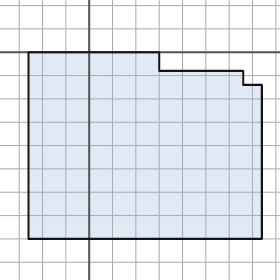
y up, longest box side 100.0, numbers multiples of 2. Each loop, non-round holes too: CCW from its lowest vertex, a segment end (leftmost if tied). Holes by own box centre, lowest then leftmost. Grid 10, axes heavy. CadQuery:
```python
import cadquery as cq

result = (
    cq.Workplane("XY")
    .moveTo(-26.0, -80.0)
    .lineTo(74.0, -80.0)
    .lineTo(74.0, -14.0)
    .lineTo(66.0, -14.0)
    .lineTo(66.0, -8.0)
    .lineTo(30.0, -8.0)
    .lineTo(30.0, 0.0)
    .lineTo(-26.0, 0.0)
    .close()
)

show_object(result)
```